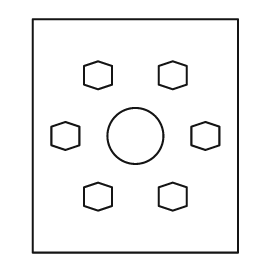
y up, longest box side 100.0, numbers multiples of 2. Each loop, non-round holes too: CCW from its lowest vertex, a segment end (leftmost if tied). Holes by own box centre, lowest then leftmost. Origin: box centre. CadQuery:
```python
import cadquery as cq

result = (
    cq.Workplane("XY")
    .moveTo(-44.0, -50.0)
    .lineTo(44.0, -50.0)
    .lineTo(44.0, 50.0)
    .lineTo(-44.0, 50.0)
    .close()
    .moveTo(-16.0, -32.0)
    .lineTo(-10.0, -30.0)
    .lineTo(-10.0, -22.0)
    .lineTo(-16.0, -20.0)
    .lineTo(-22.0, -22.0)
    .lineTo(-22.0, -30.0)
    .close()
    .moveTo(16.0, -32.0)
    .lineTo(22.0, -30.0)
    .lineTo(22.0, -22.0)
    .lineTo(16.0, -20.0)
    .lineTo(10.0, -22.0)
    .lineTo(10.0, -30.0)
    .close()
    .moveTo(-30.0, -6.0)
    .lineTo(-24.0, -4.0)
    .lineTo(-24.0, 4.0)
    .lineTo(-30.0, 6.0)
    .lineTo(-36.0, 4.0)
    .lineTo(-36.0, -4.0)
    .close()
    .moveTo(0.0, 0.0)
    .circle(12.0)
    .moveTo(30.0, -6.0)
    .lineTo(36.0, -4.0)
    .lineTo(36.0, 4.0)
    .lineTo(30.0, 6.0)
    .lineTo(24.0, 4.0)
    .lineTo(24.0, -4.0)
    .close()
    .moveTo(-16.0, 20.0)
    .lineTo(-10.0, 22.0)
    .lineTo(-10.0, 30.0)
    .lineTo(-16.0, 32.0)
    .lineTo(-22.0, 30.0)
    .lineTo(-22.0, 22.0)
    .close()
    .moveTo(16.0, 20.0)
    .lineTo(22.0, 22.0)
    .lineTo(22.0, 30.0)
    .lineTo(16.0, 32.0)
    .lineTo(10.0, 30.0)
    .lineTo(10.0, 22.0)
    .close()
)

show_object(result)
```